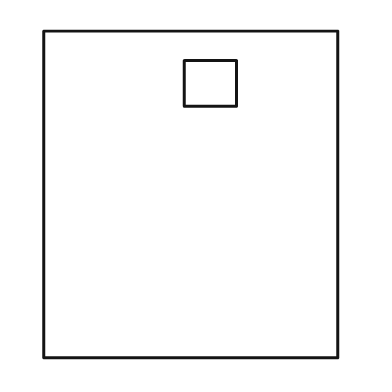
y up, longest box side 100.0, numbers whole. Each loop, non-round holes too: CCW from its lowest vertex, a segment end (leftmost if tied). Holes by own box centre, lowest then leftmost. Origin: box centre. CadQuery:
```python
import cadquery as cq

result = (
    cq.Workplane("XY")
    .moveTo(-45.0, -50.0)
    .lineTo(45.0, -50.0)
    .lineTo(45.0, 50.0)
    .lineTo(-45.0, 50.0)
    .close()
    .moveTo(-2.0, 27.0)
    .lineTo(14.0, 27.0)
    .lineTo(14.0, 41.0)
    .lineTo(-2.0, 41.0)
    .close()
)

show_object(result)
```